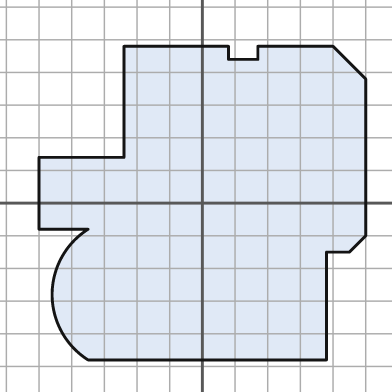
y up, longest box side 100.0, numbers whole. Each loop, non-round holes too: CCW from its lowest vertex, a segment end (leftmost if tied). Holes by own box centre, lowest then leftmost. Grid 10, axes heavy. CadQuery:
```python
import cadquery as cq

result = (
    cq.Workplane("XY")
    .moveTo(-35.0, -48.0)
    .lineTo(38.0, -48.0)
    .lineTo(38.0, -15.0)
    .lineTo(45.0, -15.0)
    .lineTo(50.0, -10.0)
    .lineTo(50.0, 38.0)
    .lineTo(40.0, 48.0)
    .lineTo(17.0, 48.0)
    .lineTo(17.0, 44.0)
    .lineTo(8.0, 44.0)
    .lineTo(8.0, 48.0)
    .lineTo(-24.0, 48.0)
    .lineTo(-24.0, 14.0)
    .lineTo(-50.0, 14.0)
    .lineTo(-50.0, -8.0)
    .lineTo(-35.0, -8.0)
    .threePointArc((-46.0, -28.0), (-35.0, -48.0))
    .close()
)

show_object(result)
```